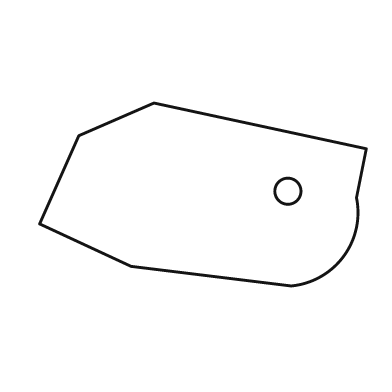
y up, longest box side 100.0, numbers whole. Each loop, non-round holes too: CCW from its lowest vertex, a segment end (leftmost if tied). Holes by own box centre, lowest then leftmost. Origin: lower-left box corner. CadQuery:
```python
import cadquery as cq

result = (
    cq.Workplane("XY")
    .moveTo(77.0, 0.0)
    .threePointArc((93.0, 9.0), (97.0, 27.0))
    .lineTo(100.0, 42.0)
    .lineTo(35.0, 56.0)
    .lineTo(12.0, 46.0)
    .lineTo(0.0, 19.0)
    .lineTo(28.0, 6.0)
    .close()
    .moveTo(76.0, 29.0)
    .circle(4.0)
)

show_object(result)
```